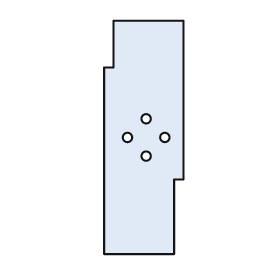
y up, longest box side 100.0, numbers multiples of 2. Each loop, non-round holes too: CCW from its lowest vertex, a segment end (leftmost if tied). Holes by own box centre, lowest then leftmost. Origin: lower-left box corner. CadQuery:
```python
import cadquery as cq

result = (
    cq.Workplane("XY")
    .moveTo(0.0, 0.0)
    .lineTo(30.0, 0.0)
    .lineTo(30.0, 32.0)
    .lineTo(34.0, 32.0)
    .lineTo(34.0, 100.0)
    .lineTo(4.0, 100.0)
    .lineTo(4.0, 80.0)
    .lineTo(0.0, 80.0)
    .close()
    .moveTo(18.0, 42.0)
    .circle(2.0)
    .moveTo(10.0, 50.0)
    .circle(2.0)
    .moveTo(26.0, 50.0)
    .circle(2.0)
    .moveTo(18.0, 58.0)
    .circle(2.0)
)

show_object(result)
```